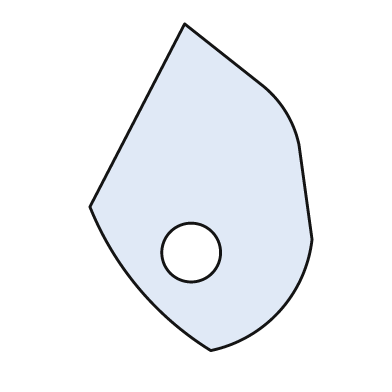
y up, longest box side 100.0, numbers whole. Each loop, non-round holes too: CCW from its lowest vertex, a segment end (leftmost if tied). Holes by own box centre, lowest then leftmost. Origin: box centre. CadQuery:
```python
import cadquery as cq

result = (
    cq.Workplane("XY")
    .moveTo(3.0, -50.0)
    .threePointArc((24.0, -38.0), (34.0, -16.0))
    .lineTo(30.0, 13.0)
    .threePointArc((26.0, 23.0), (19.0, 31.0))
    .lineTo(-5.0, 50.0)
    .lineTo(-34.0, -6.0)
    .threePointArc((-19.0, -31.0), (3.0, -50.0))
    .close()
    .moveTo(-3.0, -20.0)
    .circle(9.0)
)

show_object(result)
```